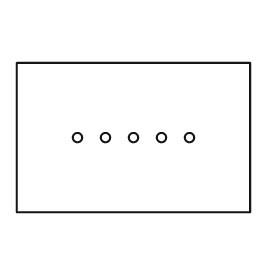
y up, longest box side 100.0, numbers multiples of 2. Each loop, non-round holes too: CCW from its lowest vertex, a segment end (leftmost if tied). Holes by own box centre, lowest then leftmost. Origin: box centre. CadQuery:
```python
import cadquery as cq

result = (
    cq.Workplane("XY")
    .moveTo(-50.0, -32.0)
    .lineTo(50.0, -32.0)
    .lineTo(50.0, 32.0)
    .lineTo(-50.0, 32.0)
    .close()
    .moveTo(-24.0, 0.0)
    .circle(2.0)
    .moveTo(-12.0, 0.0)
    .circle(2.0)
    .moveTo(0.0, 0.0)
    .circle(2.0)
    .moveTo(12.0, 0.0)
    .circle(2.0)
    .moveTo(24.0, 0.0)
    .circle(2.0)
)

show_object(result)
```